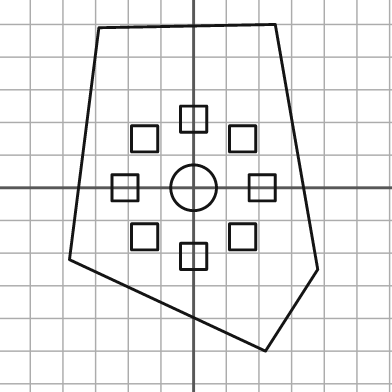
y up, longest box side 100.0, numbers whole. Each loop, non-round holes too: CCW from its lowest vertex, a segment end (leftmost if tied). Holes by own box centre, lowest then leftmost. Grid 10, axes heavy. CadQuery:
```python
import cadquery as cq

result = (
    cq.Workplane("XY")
    .moveTo(22.0, -50.0)
    .lineTo(38.0, -25.0)
    .lineTo(25.0, 50.0)
    .lineTo(-29.0, 49.0)
    .lineTo(-38.0, -22.0)
    .close()
    .moveTo(-4.0, -25.0)
    .lineTo(4.0, -25.0)
    .lineTo(4.0, -17.0)
    .lineTo(-4.0, -17.0)
    .close()
    .moveTo(-19.0, -19.0)
    .lineTo(-11.0, -19.0)
    .lineTo(-11.0, -11.0)
    .lineTo(-19.0, -11.0)
    .close()
    .moveTo(11.0, -19.0)
    .lineTo(19.0, -19.0)
    .lineTo(19.0, -11.0)
    .lineTo(11.0, -11.0)
    .close()
    .moveTo(-25.0, -4.0)
    .lineTo(-17.0, -4.0)
    .lineTo(-17.0, 4.0)
    .lineTo(-25.0, 4.0)
    .close()
    .moveTo(0.0, 0.0)
    .circle(7.0)
    .moveTo(17.0, -4.0)
    .lineTo(25.0, -4.0)
    .lineTo(25.0, 4.0)
    .lineTo(17.0, 4.0)
    .close()
    .moveTo(-19.0, 11.0)
    .lineTo(-11.0, 11.0)
    .lineTo(-11.0, 19.0)
    .lineTo(-19.0, 19.0)
    .close()
    .moveTo(11.0, 11.0)
    .lineTo(19.0, 11.0)
    .lineTo(19.0, 19.0)
    .lineTo(11.0, 19.0)
    .close()
    .moveTo(-4.0, 17.0)
    .lineTo(4.0, 17.0)
    .lineTo(4.0, 25.0)
    .lineTo(-4.0, 25.0)
    .close()
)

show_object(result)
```